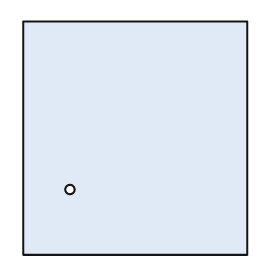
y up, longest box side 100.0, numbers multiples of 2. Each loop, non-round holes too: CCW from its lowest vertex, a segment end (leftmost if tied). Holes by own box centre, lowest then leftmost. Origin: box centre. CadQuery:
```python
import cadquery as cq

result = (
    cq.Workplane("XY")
    .moveTo(-48.0, -50.0)
    .lineTo(48.0, -50.0)
    .lineTo(48.0, 50.0)
    .lineTo(-48.0, 50.0)
    .close()
    .moveTo(-28.0, -22.0)
    .circle(2.0)
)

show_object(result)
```